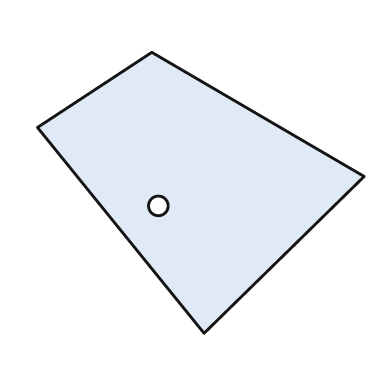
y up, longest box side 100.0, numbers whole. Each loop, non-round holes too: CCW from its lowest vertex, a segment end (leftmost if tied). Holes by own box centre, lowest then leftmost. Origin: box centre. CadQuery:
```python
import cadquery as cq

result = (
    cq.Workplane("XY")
    .moveTo(1.0, -43.0)
    .lineTo(50.0, 5.0)
    .lineTo(-15.0, 43.0)
    .lineTo(-50.0, 20.0)
    .close()
    .moveTo(-13.0, -4.0)
    .circle(3.0)
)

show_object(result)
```